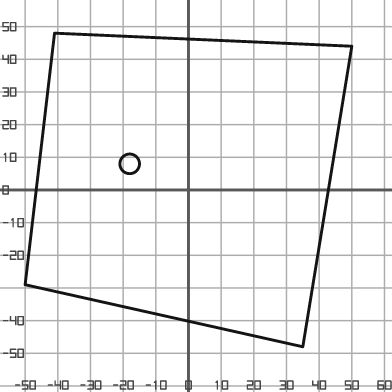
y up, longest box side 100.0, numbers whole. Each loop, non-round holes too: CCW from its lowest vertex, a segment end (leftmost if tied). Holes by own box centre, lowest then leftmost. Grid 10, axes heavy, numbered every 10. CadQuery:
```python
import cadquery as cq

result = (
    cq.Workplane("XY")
    .moveTo(35.0, -48.0)
    .lineTo(50.0, 44.0)
    .lineTo(-41.0, 48.0)
    .lineTo(-50.0, -29.0)
    .close()
    .moveTo(-18.0, 8.0)
    .circle(3.0)
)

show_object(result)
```